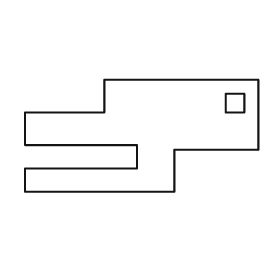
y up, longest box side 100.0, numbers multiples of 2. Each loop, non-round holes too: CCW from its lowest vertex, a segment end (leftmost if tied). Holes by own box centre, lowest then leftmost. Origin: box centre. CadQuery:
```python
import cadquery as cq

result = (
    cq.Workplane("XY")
    .moveTo(-50.0, -24.0)
    .lineTo(14.0, -24.0)
    .lineTo(14.0, -6.0)
    .lineTo(50.0, -6.0)
    .lineTo(50.0, 24.0)
    .lineTo(-16.0, 24.0)
    .lineTo(-16.0, 10.0)
    .lineTo(-50.0, 10.0)
    .lineTo(-50.0, -4.0)
    .lineTo(-2.0, -4.0)
    .lineTo(-2.0, -14.0)
    .lineTo(-50.0, -14.0)
    .close()
    .moveTo(36.0, 10.0)
    .lineTo(44.0, 10.0)
    .lineTo(44.0, 18.0)
    .lineTo(36.0, 18.0)
    .close()
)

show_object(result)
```